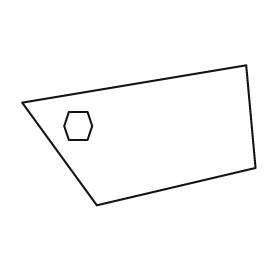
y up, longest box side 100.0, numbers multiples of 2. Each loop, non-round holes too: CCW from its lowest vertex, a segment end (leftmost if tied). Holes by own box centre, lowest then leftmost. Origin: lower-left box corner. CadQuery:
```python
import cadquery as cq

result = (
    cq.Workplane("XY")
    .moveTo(32.0, 0.0)
    .lineTo(100.0, 16.0)
    .lineTo(96.0, 60.0)
    .lineTo(0.0, 44.0)
    .close()
    .moveTo(20.0, 28.0)
    .lineTo(28.0, 28.0)
    .lineTo(30.0, 34.0)
    .lineTo(28.0, 40.0)
    .lineTo(20.0, 40.0)
    .lineTo(18.0, 34.0)
    .close()
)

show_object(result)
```